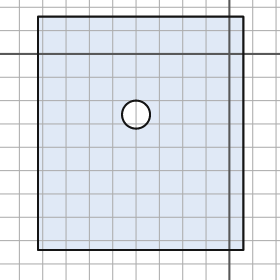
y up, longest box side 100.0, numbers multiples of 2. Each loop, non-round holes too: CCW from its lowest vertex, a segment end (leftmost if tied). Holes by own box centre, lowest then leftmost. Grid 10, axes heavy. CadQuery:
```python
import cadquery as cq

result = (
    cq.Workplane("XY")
    .moveTo(-82.0, -84.0)
    .lineTo(6.0, -84.0)
    .lineTo(6.0, 16.0)
    .lineTo(-82.0, 16.0)
    .close()
    .moveTo(-40.0, -26.0)
    .circle(6.0)
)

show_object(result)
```